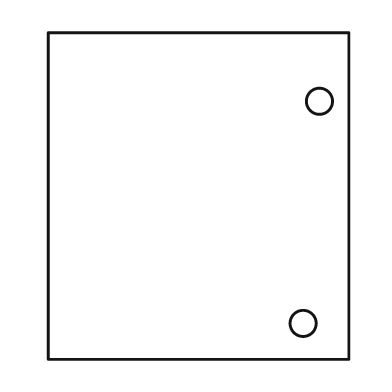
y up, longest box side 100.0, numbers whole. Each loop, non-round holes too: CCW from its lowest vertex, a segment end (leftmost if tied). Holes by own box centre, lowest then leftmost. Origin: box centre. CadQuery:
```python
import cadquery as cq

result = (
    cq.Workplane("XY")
    .moveTo(-46.0, -50.0)
    .lineTo(46.0, -50.0)
    .lineTo(46.0, 50.0)
    .lineTo(-46.0, 50.0)
    .close()
    .moveTo(32.0, -39.0)
    .circle(4.0)
    .moveTo(37.0, 29.0)
    .circle(4.0)
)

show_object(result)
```